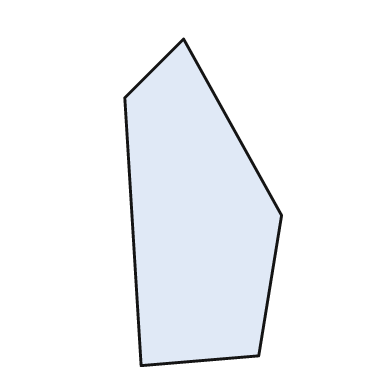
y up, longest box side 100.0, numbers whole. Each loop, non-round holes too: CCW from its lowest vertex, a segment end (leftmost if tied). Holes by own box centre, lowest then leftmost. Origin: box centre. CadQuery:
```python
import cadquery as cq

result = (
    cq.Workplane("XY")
    .moveTo(-19.0, -50.0)
    .lineTo(17.0, -47.0)
    .lineTo(24.0, -4.0)
    .lineTo(-6.0, 50.0)
    .lineTo(-24.0, 32.0)
    .close()
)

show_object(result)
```